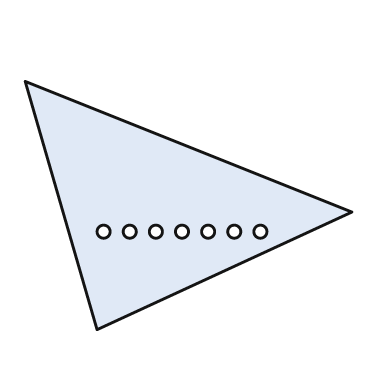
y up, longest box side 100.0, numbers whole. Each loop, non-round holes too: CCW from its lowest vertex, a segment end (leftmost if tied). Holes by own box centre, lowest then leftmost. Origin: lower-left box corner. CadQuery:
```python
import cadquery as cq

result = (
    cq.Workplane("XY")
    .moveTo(22.0, 0.0)
    .lineTo(100.0, 36.0)
    .lineTo(0.0, 76.0)
    .close()
    .moveTo(24.0, 30.0)
    .circle(2.0)
    .moveTo(32.0, 30.0)
    .circle(2.0)
    .moveTo(40.0, 30.0)
    .circle(2.0)
    .moveTo(48.0, 30.0)
    .circle(2.0)
    .moveTo(56.0, 30.0)
    .circle(2.0)
    .moveTo(64.0, 30.0)
    .circle(2.0)
    .moveTo(72.0, 30.0)
    .circle(2.0)
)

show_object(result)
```